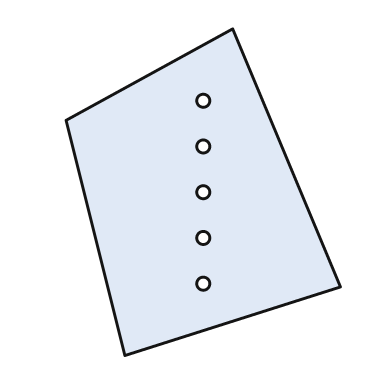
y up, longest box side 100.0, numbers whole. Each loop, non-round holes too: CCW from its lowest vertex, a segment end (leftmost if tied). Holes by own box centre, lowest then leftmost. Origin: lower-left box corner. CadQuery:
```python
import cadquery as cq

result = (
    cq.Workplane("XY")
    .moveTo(18.0, 0.0)
    .lineTo(84.0, 21.0)
    .lineTo(51.0, 100.0)
    .lineTo(0.0, 72.0)
    .close()
    .moveTo(42.0, 22.0)
    .circle(2.0)
    .moveTo(42.0, 36.0)
    .circle(2.0)
    .moveTo(42.0, 50.0)
    .circle(2.0)
    .moveTo(42.0, 64.0)
    .circle(2.0)
    .moveTo(42.0, 78.0)
    .circle(2.0)
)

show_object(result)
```